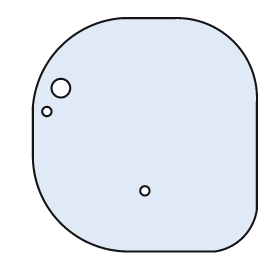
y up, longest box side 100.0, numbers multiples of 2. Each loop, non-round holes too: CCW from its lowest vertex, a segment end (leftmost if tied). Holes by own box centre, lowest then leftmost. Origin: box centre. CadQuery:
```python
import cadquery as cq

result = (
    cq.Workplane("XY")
    .moveTo(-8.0, -50.0)
    .lineTo(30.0, -50.0)
    .threePointArc((42.0, -44.0), (48.0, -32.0))
    .lineTo(48.0, 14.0)
    .threePointArc((38.0, 40.0), (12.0, 50.0))
    .lineTo(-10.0, 50.0)
    .threePointArc((-36.0, 38.0), (-48.0, 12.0))
    .lineTo(-48.0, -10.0)
    .threePointArc((-36.0, -38.0), (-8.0, -50.0))
    .close()
    .moveTo(0.0, -24.0)
    .circle(2.0)
    .moveTo(-42.0, 10.0)
    .circle(2.0)
    .moveTo(-36.0, 20.0)
    .circle(4.0)
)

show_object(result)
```